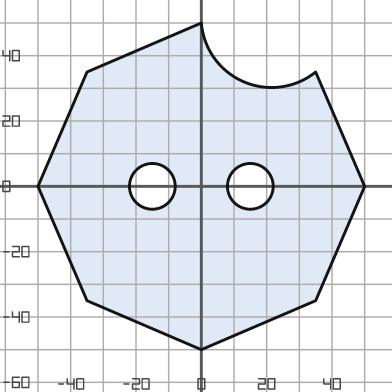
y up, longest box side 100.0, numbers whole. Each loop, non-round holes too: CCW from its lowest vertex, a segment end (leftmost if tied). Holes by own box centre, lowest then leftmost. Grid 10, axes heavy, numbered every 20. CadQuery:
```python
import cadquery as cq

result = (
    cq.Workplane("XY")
    .moveTo(0.0, -50.0)
    .lineTo(35.0, -35.0)
    .lineTo(50.0, 0.0)
    .lineTo(35.0, 35.0)
    .threePointArc((13.0, 32.0), (0.0, 50.0))
    .lineTo(-35.0, 35.0)
    .lineTo(-50.0, 0.0)
    .lineTo(-35.0, -35.0)
    .close()
    .moveTo(-15.0, 0.0)
    .circle(7.0)
    .moveTo(15.0, 0.0)
    .circle(7.0)
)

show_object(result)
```